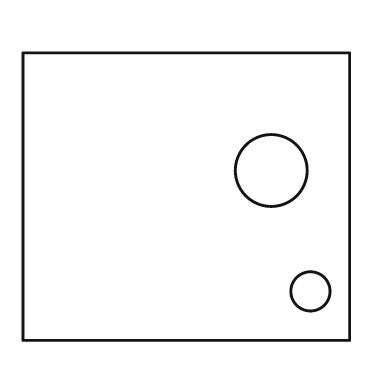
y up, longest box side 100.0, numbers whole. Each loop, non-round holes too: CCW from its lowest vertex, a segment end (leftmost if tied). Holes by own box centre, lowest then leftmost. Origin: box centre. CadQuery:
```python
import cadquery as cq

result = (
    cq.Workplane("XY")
    .moveTo(-50.0, -44.0)
    .lineTo(50.0, -44.0)
    .lineTo(50.0, 44.0)
    .lineTo(-50.0, 44.0)
    .close()
    .moveTo(38.0, -29.0)
    .circle(6.0)
    .moveTo(26.0, 8.0)
    .circle(11.0)
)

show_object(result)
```